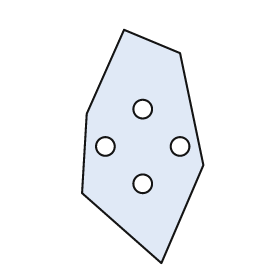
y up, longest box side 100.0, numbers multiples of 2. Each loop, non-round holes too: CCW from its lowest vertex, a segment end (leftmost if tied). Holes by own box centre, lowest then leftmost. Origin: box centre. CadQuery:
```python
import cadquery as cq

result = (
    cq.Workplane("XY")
    .moveTo(8.0, -50.0)
    .lineTo(26.0, -8.0)
    .lineTo(16.0, 40.0)
    .lineTo(-8.0, 50.0)
    .lineTo(-24.0, 14.0)
    .lineTo(-26.0, -20.0)
    .close()
    .moveTo(0.0, -16.0)
    .circle(4.0)
    .moveTo(-16.0, 0.0)
    .circle(4.0)
    .moveTo(16.0, 0.0)
    .circle(4.0)
    .moveTo(0.0, 16.0)
    .circle(4.0)
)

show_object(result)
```